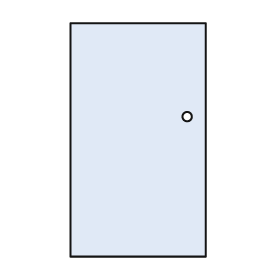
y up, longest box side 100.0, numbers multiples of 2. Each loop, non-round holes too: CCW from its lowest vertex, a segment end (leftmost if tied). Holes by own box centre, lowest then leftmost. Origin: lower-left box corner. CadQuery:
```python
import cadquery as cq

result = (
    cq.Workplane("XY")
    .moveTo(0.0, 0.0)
    .lineTo(58.0, 0.0)
    .lineTo(58.0, 100.0)
    .lineTo(0.0, 100.0)
    .close()
    .moveTo(50.0, 60.0)
    .circle(2.0)
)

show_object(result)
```